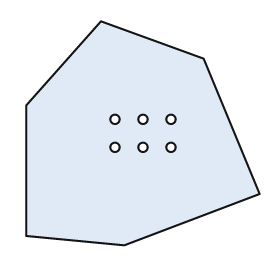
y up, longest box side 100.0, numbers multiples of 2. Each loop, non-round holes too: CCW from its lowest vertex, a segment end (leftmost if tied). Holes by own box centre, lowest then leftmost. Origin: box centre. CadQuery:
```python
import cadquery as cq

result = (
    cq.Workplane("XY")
    .moveTo(-8.0, -48.0)
    .lineTo(50.0, -26.0)
    .lineTo(26.0, 32.0)
    .lineTo(-18.0, 48.0)
    .lineTo(-50.0, 12.0)
    .lineTo(-50.0, -44.0)
    .close()
    .moveTo(-12.0, -6.0)
    .circle(2.0)
    .moveTo(0.0, -6.0)
    .circle(2.0)
    .moveTo(12.0, -6.0)
    .circle(2.0)
    .moveTo(-12.0, 6.0)
    .circle(2.0)
    .moveTo(0.0, 6.0)
    .circle(2.0)
    .moveTo(12.0, 6.0)
    .circle(2.0)
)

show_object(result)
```